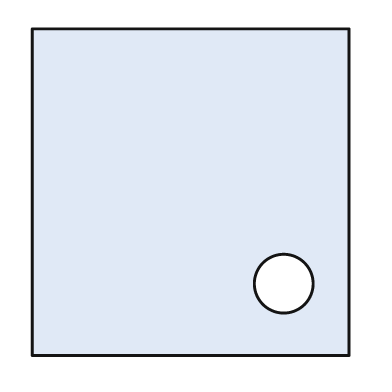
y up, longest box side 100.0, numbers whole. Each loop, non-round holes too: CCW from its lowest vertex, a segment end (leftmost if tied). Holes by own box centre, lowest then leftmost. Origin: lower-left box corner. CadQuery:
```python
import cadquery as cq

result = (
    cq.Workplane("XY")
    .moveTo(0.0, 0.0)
    .lineTo(97.0, 0.0)
    .lineTo(97.0, 100.0)
    .lineTo(0.0, 100.0)
    .close()
    .moveTo(77.0, 22.0)
    .circle(9.0)
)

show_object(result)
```